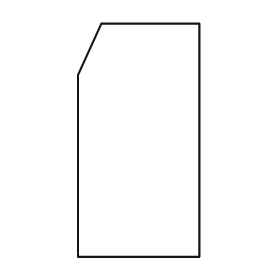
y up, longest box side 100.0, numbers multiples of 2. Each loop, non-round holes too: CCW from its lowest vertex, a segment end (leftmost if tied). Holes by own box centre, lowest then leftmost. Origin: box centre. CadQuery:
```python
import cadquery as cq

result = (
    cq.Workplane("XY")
    .moveTo(-26.0, -50.0)
    .lineTo(26.0, -50.0)
    .lineTo(26.0, 50.0)
    .lineTo(-16.0, 50.0)
    .lineTo(-26.0, 28.0)
    .close()
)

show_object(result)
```